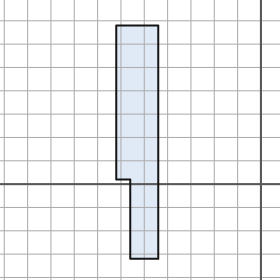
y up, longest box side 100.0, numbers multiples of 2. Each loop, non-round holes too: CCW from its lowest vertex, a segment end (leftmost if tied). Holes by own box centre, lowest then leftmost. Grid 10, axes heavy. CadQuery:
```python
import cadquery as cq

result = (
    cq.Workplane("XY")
    .moveTo(-56.0, -32.0)
    .lineTo(-44.0, -32.0)
    .lineTo(-44.0, 68.0)
    .lineTo(-62.0, 68.0)
    .lineTo(-62.0, 2.0)
    .lineTo(-56.0, 2.0)
    .close()
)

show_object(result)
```